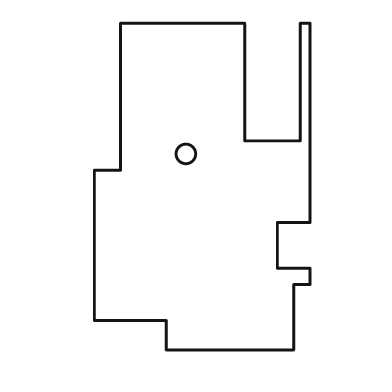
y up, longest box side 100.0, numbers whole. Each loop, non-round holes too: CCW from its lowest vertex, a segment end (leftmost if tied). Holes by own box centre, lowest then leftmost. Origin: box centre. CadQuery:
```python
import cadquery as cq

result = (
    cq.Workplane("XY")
    .moveTo(-11.0, -50.0)
    .lineTo(28.0, -50.0)
    .lineTo(28.0, -30.0)
    .lineTo(33.0, -30.0)
    .lineTo(33.0, -25.0)
    .lineTo(23.0, -25.0)
    .lineTo(23.0, -11.0)
    .lineTo(33.0, -11.0)
    .lineTo(33.0, 50.0)
    .lineTo(30.0, 50.0)
    .lineTo(30.0, 14.0)
    .lineTo(13.0, 14.0)
    .lineTo(13.0, 50.0)
    .lineTo(-25.0, 50.0)
    .lineTo(-25.0, 5.0)
    .lineTo(-33.0, 5.0)
    .lineTo(-33.0, -41.0)
    .lineTo(-11.0, -41.0)
    .close()
    .moveTo(-5.0, 10.0)
    .circle(3.0)
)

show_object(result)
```